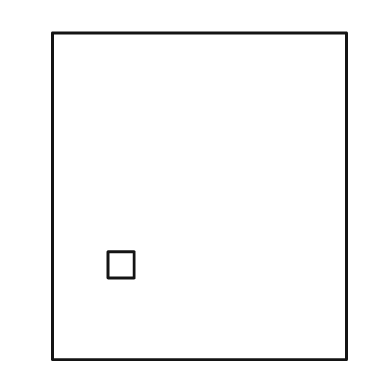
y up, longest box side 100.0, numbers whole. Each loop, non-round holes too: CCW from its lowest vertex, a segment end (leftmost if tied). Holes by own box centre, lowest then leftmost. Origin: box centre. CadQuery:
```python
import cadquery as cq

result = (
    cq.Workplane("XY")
    .moveTo(-45.0, -50.0)
    .lineTo(45.0, -50.0)
    .lineTo(45.0, 50.0)
    .lineTo(-45.0, 50.0)
    .close()
    .moveTo(-28.0, -25.0)
    .lineTo(-20.0, -25.0)
    .lineTo(-20.0, -17.0)
    .lineTo(-28.0, -17.0)
    .close()
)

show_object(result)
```